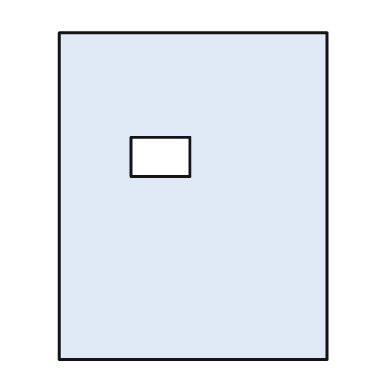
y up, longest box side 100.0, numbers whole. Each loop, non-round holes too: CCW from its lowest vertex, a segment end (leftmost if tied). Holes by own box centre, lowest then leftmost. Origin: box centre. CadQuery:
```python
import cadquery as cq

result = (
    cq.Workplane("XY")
    .moveTo(-41.0, -50.0)
    .lineTo(41.0, -50.0)
    .lineTo(41.0, 50.0)
    .lineTo(-41.0, 50.0)
    .close()
    .moveTo(-19.0, 6.0)
    .lineTo(-1.0, 6.0)
    .lineTo(-1.0, 18.0)
    .lineTo(-19.0, 18.0)
    .close()
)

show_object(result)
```